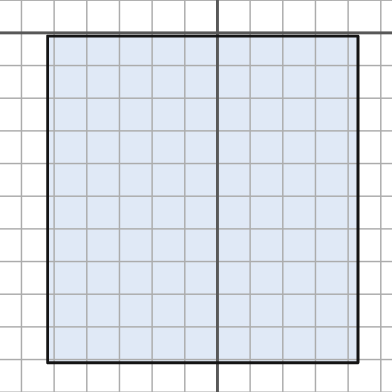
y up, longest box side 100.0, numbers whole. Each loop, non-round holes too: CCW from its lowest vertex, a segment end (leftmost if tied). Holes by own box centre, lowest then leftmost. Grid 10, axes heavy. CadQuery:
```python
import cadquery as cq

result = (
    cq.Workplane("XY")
    .moveTo(-52.0, -101.0)
    .lineTo(43.0, -101.0)
    .lineTo(43.0, -1.0)
    .lineTo(-52.0, -1.0)
    .close()
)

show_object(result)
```